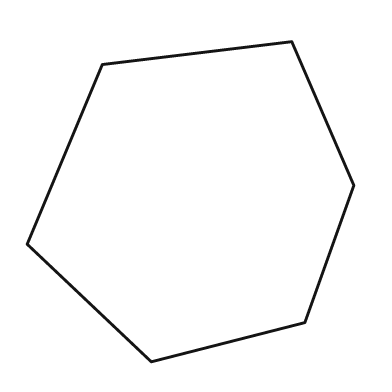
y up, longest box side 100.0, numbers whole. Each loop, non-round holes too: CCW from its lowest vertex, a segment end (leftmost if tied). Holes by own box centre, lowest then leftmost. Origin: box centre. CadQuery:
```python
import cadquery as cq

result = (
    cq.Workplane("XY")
    .moveTo(-12.0, -49.0)
    .lineTo(35.0, -37.0)
    .lineTo(50.0, 5.0)
    .lineTo(31.0, 49.0)
    .lineTo(-27.0, 42.0)
    .lineTo(-50.0, -13.0)
    .close()
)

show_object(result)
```